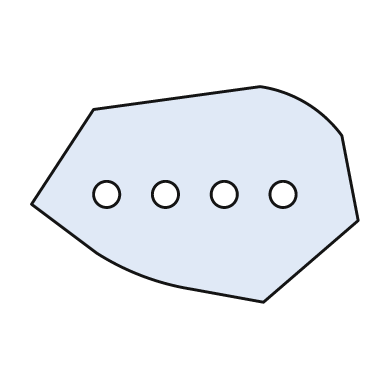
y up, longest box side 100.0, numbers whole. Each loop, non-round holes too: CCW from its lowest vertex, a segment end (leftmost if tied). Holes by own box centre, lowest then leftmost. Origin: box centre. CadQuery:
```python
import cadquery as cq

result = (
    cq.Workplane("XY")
    .moveTo(21.0, -33.0)
    .lineTo(50.0, -8.0)
    .lineTo(45.0, 18.0)
    .threePointArc((34.0, 28.0), (20.0, 33.0))
    .lineTo(-31.0, 26.0)
    .lineTo(-50.0, -3.0)
    .lineTo(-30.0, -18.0)
    .threePointArc((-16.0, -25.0), (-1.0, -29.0))
    .close()
    .moveTo(-27.0, 0.0)
    .circle(4.0)
    .moveTo(-9.0, 0.0)
    .circle(4.0)
    .moveTo(9.0, 0.0)
    .circle(4.0)
    .moveTo(27.0, 0.0)
    .circle(4.0)
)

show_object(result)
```